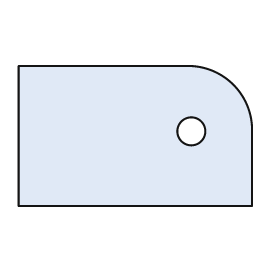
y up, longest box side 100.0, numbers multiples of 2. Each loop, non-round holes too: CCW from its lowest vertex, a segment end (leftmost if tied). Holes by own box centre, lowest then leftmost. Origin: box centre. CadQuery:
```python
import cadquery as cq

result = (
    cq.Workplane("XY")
    .moveTo(-50.0, -30.0)
    .lineTo(50.0, -30.0)
    .lineTo(50.0, 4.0)
    .threePointArc((42.0, 22.0), (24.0, 30.0))
    .lineTo(-50.0, 30.0)
    .close()
    .moveTo(24.0, 2.0)
    .circle(6.0)
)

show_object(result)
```